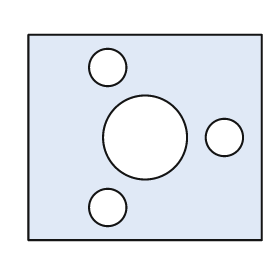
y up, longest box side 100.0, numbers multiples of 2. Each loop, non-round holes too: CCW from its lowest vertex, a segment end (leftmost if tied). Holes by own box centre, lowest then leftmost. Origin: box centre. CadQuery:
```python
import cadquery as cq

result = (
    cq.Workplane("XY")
    .moveTo(-50.0, -44.0)
    .lineTo(50.0, -44.0)
    .lineTo(50.0, 44.0)
    .lineTo(-50.0, 44.0)
    .close()
    .moveTo(-16.0, -30.0)
    .circle(8.0)
    .moveTo(0.0, 0.0)
    .circle(18.0)
    .moveTo(34.0, 0.0)
    .circle(8.0)
    .moveTo(-16.0, 30.0)
    .circle(8.0)
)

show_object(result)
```